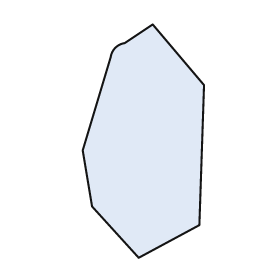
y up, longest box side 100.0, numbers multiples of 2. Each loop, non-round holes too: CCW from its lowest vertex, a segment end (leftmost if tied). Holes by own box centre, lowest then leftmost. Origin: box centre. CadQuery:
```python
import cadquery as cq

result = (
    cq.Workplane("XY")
    .moveTo(-2.0, -50.0)
    .lineTo(24.0, -36.0)
    .lineTo(26.0, 24.0)
    .lineTo(4.0, 50.0)
    .lineTo(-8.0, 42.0)
    .threePointArc((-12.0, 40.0), (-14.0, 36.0))
    .lineTo(-26.0, -4.0)
    .lineTo(-22.0, -28.0)
    .close()
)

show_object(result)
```